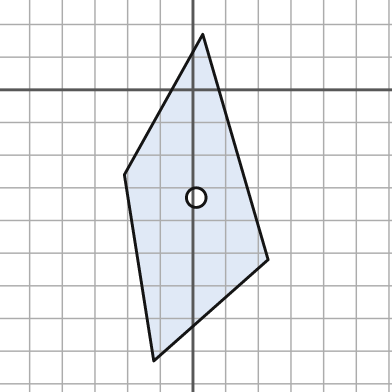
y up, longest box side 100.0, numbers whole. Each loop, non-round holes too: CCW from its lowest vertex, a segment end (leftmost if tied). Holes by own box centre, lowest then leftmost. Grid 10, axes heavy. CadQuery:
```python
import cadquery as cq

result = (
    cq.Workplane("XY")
    .moveTo(-12.0, -83.0)
    .lineTo(23.0, -52.0)
    .lineTo(3.0, 17.0)
    .lineTo(-21.0, -26.0)
    .close()
    .moveTo(1.0, -33.0)
    .circle(3.0)
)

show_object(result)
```